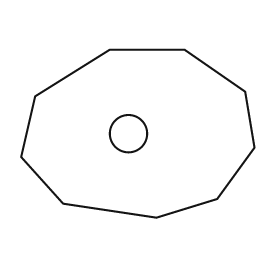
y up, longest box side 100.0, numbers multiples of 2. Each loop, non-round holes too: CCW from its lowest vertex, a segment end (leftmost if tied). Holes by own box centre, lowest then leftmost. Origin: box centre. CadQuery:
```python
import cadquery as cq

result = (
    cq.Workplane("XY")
    .moveTo(8.0, -36.0)
    .lineTo(34.0, -28.0)
    .lineTo(50.0, -6.0)
    .lineTo(46.0, 18.0)
    .lineTo(20.0, 36.0)
    .lineTo(-12.0, 36.0)
    .lineTo(-44.0, 16.0)
    .lineTo(-50.0, -10.0)
    .lineTo(-32.0, -30.0)
    .close()
    .moveTo(-4.0, 0.0)
    .circle(8.0)
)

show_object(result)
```